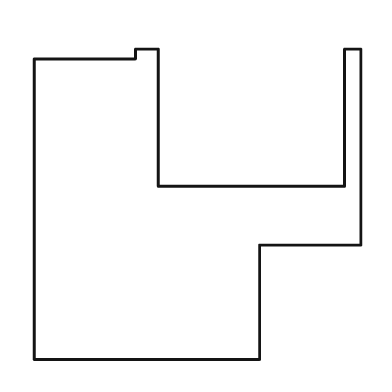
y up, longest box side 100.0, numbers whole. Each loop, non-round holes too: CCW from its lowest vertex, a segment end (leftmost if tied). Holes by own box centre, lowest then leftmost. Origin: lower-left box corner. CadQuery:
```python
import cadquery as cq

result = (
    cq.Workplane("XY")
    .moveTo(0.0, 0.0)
    .lineTo(69.0, 0.0)
    .lineTo(69.0, 35.0)
    .lineTo(100.0, 35.0)
    .lineTo(100.0, 95.0)
    .lineTo(95.0, 95.0)
    .lineTo(95.0, 53.0)
    .lineTo(38.0, 53.0)
    .lineTo(38.0, 95.0)
    .lineTo(31.0, 95.0)
    .lineTo(31.0, 92.0)
    .lineTo(0.0, 92.0)
    .close()
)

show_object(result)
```